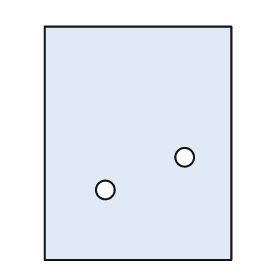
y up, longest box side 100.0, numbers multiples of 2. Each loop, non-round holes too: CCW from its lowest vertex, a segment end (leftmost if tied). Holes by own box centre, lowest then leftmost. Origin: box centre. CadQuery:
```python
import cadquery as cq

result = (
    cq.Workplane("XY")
    .moveTo(-40.0, -50.0)
    .lineTo(40.0, -50.0)
    .lineTo(40.0, 50.0)
    .lineTo(-40.0, 50.0)
    .close()
    .moveTo(-14.0, -20.0)
    .circle(4.0)
    .moveTo(20.0, -6.0)
    .circle(4.0)
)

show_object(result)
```